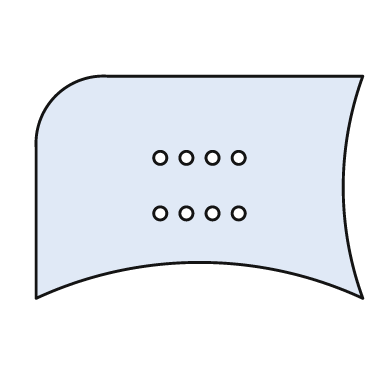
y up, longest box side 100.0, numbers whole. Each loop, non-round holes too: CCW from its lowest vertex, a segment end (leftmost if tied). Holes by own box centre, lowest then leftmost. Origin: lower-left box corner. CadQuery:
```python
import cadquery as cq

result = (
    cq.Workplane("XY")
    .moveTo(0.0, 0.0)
    .threePointArc((50.0, 11.0), (100.0, 0.0))
    .threePointArc((94.0, 34.0), (100.0, 68.0))
    .lineTo(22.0, 68.0)
    .threePointArc((6.0, 62.0), (0.0, 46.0))
    .close()
    .moveTo(38.0, 26.0)
    .circle(2.0)
    .moveTo(46.0, 26.0)
    .circle(2.0)
    .moveTo(54.0, 26.0)
    .circle(2.0)
    .moveTo(62.0, 26.0)
    .circle(2.0)
    .moveTo(38.0, 43.0)
    .circle(2.0)
    .moveTo(46.0, 43.0)
    .circle(2.0)
    .moveTo(54.0, 43.0)
    .circle(2.0)
    .moveTo(62.0, 43.0)
    .circle(2.0)
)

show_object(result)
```